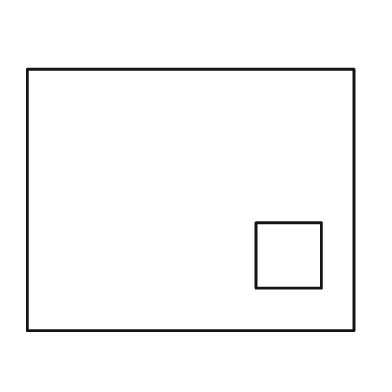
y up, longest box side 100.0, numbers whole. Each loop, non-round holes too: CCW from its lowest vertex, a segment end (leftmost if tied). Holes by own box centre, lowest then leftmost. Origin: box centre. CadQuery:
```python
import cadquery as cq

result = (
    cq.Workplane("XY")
    .moveTo(-50.0, -40.0)
    .lineTo(50.0, -40.0)
    .lineTo(50.0, 40.0)
    .lineTo(-50.0, 40.0)
    .close()
    .moveTo(20.0, -27.0)
    .lineTo(40.0, -27.0)
    .lineTo(40.0, -7.0)
    .lineTo(20.0, -7.0)
    .close()
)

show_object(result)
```